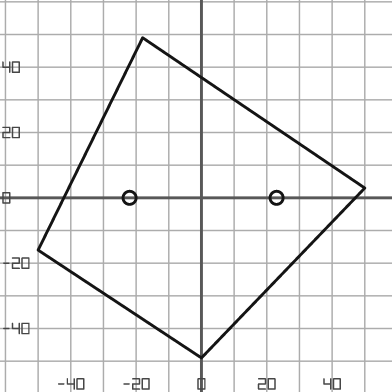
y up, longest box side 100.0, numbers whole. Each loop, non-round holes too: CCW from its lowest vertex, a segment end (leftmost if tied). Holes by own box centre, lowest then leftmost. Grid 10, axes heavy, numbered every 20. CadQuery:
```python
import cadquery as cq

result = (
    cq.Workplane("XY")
    .moveTo(0.0, -49.0)
    .lineTo(50.0, 3.0)
    .lineTo(-18.0, 49.0)
    .lineTo(-50.0, -16.0)
    .close()
    .moveTo(-22.0, 0.0)
    .circle(2.0)
    .moveTo(23.0, 0.0)
    .circle(2.0)
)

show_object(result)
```